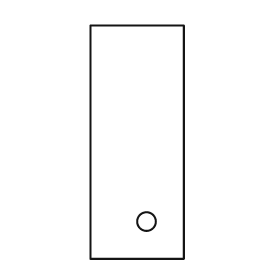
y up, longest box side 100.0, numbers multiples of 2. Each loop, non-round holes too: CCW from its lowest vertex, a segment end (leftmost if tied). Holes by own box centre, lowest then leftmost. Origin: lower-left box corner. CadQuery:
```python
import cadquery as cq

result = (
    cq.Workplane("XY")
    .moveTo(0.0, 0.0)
    .lineTo(40.0, 0.0)
    .lineTo(40.0, 100.0)
    .lineTo(0.0, 100.0)
    .close()
    .moveTo(24.0, 16.0)
    .circle(4.0)
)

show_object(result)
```